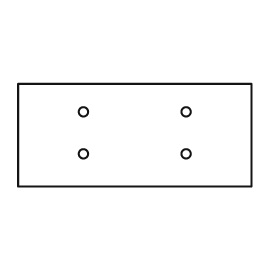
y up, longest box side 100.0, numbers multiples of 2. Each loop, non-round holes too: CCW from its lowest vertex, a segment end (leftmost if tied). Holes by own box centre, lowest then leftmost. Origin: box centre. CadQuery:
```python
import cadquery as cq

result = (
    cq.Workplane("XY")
    .moveTo(-50.0, -22.0)
    .lineTo(50.0, -22.0)
    .lineTo(50.0, 22.0)
    .lineTo(-50.0, 22.0)
    .close()
    .moveTo(-22.0, -8.0)
    .circle(2.0)
    .moveTo(22.0, -8.0)
    .circle(2.0)
    .moveTo(-22.0, 10.0)
    .circle(2.0)
    .moveTo(22.0, 10.0)
    .circle(2.0)
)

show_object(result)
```